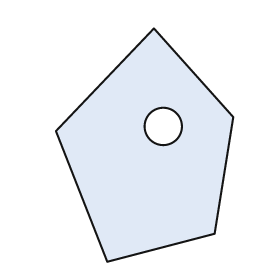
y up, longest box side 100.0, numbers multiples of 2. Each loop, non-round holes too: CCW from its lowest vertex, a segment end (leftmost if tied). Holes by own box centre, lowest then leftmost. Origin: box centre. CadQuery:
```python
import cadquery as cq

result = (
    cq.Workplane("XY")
    .moveTo(-16.0, -50.0)
    .lineTo(30.0, -38.0)
    .lineTo(38.0, 12.0)
    .lineTo(4.0, 50.0)
    .lineTo(-38.0, 6.0)
    .close()
    .moveTo(8.0, 8.0)
    .circle(8.0)
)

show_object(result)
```